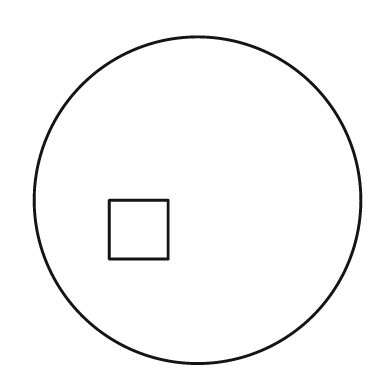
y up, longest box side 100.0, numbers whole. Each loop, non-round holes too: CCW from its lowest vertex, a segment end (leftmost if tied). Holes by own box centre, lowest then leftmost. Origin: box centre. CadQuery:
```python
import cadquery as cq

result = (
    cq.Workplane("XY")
    .moveTo(0.0, 0.0)
    .circle(50.0)
    .moveTo(-27.0, -18.0)
    .lineTo(-9.0, -18.0)
    .lineTo(-9.0, 0.0)
    .lineTo(-27.0, 0.0)
    .close()
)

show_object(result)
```